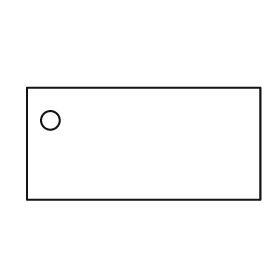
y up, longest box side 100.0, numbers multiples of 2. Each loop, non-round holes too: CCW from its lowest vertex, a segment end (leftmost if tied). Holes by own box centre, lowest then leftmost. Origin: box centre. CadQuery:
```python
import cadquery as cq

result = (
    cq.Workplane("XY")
    .moveTo(-50.0, -24.0)
    .lineTo(50.0, -24.0)
    .lineTo(50.0, 24.0)
    .lineTo(-50.0, 24.0)
    .close()
    .moveTo(-40.0, 10.0)
    .circle(4.0)
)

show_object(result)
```